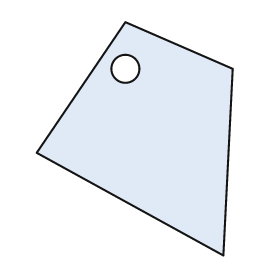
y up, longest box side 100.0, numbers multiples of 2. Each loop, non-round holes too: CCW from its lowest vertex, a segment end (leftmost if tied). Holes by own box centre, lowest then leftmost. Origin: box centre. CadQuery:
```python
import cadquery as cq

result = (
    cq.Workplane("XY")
    .moveTo(38.0, -50.0)
    .lineTo(42.0, 30.0)
    .lineTo(-4.0, 50.0)
    .lineTo(-42.0, -6.0)
    .close()
    .moveTo(-4.0, 30.0)
    .circle(6.0)
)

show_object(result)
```